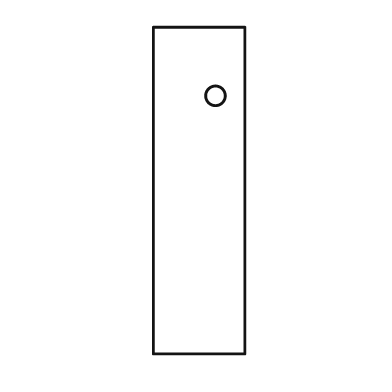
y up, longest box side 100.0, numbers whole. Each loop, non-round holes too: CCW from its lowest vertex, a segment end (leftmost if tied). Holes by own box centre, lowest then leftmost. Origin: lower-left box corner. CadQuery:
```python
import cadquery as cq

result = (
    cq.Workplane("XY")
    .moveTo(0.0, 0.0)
    .lineTo(28.0, 0.0)
    .lineTo(28.0, 100.0)
    .lineTo(0.0, 100.0)
    .close()
    .moveTo(19.0, 79.0)
    .circle(3.0)
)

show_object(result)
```